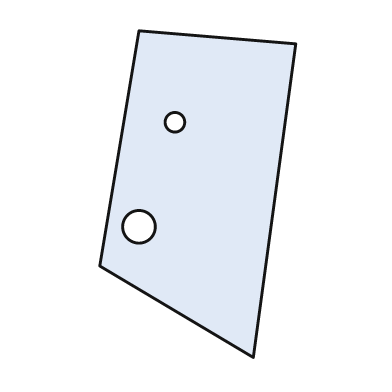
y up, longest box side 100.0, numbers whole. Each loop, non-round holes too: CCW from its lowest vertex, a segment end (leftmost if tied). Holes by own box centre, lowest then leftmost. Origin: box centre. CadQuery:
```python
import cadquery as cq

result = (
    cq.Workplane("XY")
    .moveTo(17.0, -50.0)
    .lineTo(30.0, 46.0)
    .lineTo(-18.0, 50.0)
    .lineTo(-30.0, -22.0)
    .close()
    .moveTo(-18.0, -10.0)
    .circle(5.0)
    .moveTo(-7.0, 22.0)
    .circle(3.0)
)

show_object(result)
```